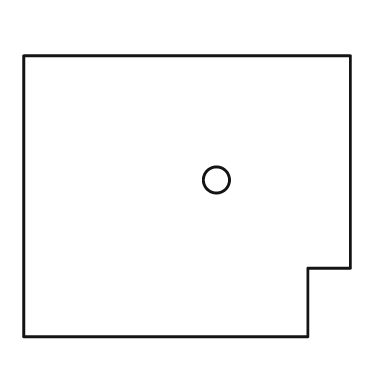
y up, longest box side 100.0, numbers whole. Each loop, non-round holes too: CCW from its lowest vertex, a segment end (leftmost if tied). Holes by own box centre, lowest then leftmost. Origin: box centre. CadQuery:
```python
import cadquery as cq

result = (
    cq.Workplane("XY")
    .moveTo(-50.0, -43.0)
    .lineTo(37.0, -43.0)
    .lineTo(37.0, -22.0)
    .lineTo(50.0, -22.0)
    .lineTo(50.0, 43.0)
    .lineTo(-50.0, 43.0)
    .close()
    .moveTo(9.0, 5.0)
    .circle(4.0)
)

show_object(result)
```